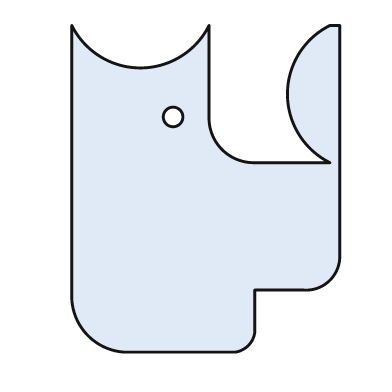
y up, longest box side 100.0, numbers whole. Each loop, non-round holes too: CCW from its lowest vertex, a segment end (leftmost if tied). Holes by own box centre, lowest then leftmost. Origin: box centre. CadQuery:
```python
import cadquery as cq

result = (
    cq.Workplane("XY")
    .moveTo(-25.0, -50.0)
    .lineTo(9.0, -50.0)
    .threePointArc((13.0, -48.0), (15.0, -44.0))
    .lineTo(15.0, -31.0)
    .lineTo(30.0, -31.0)
    .threePointArc((38.0, -28.0), (41.0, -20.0))
    .lineTo(41.0, 50.0)
    .lineTo(38.0, 50.0)
    .threePointArc((25.0, 29.0), (38.0, 8.0))
    .lineTo(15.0, 8.0)
    .threePointArc((5.0, 12.0), (1.0, 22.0))
    .lineTo(1.0, 50.0)
    .threePointArc((-20.0, 37.0), (-41.0, 50.0))
    .lineTo(-41.0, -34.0)
    .threePointArc((-36.0, -45.0), (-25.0, -50.0))
    .close()
    .moveTo(-10.0, 22.0)
    .circle(3.0)
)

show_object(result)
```